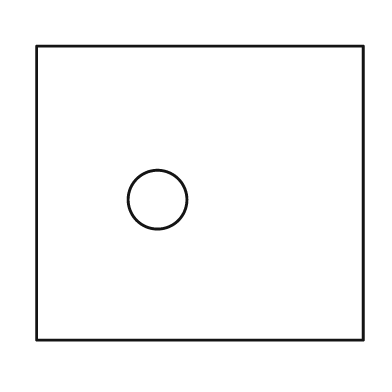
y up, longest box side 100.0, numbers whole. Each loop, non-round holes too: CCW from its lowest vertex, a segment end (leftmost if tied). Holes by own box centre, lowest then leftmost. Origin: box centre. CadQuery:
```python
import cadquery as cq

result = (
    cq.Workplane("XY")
    .moveTo(-50.0, -45.0)
    .lineTo(50.0, -45.0)
    .lineTo(50.0, 45.0)
    .lineTo(-50.0, 45.0)
    .close()
    .moveTo(-13.0, -2.0)
    .circle(9.0)
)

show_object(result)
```